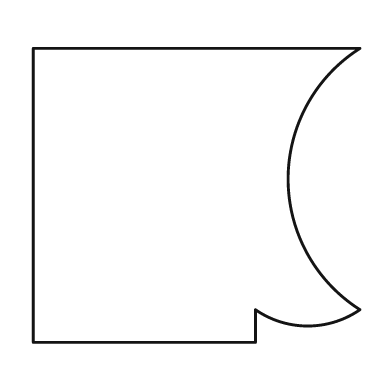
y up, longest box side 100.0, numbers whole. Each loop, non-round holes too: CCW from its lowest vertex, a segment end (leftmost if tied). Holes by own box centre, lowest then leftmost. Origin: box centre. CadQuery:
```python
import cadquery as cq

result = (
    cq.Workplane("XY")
    .moveTo(-50.0, -45.0)
    .lineTo(18.0, -45.0)
    .lineTo(18.0, -35.0)
    .threePointArc((34.0, -40.0), (50.0, -35.0))
    .threePointArc((28.0, 5.0), (50.0, 45.0))
    .lineTo(-50.0, 45.0)
    .close()
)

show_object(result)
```